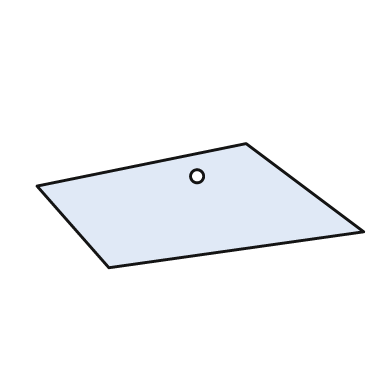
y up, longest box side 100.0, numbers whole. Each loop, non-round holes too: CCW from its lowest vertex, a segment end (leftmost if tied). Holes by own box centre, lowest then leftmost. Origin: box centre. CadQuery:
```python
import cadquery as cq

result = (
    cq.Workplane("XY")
    .moveTo(-28.0, -19.0)
    .lineTo(50.0, -8.0)
    .lineTo(14.0, 19.0)
    .lineTo(-50.0, 6.0)
    .close()
    .moveTo(-1.0, 9.0)
    .circle(2.0)
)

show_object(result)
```